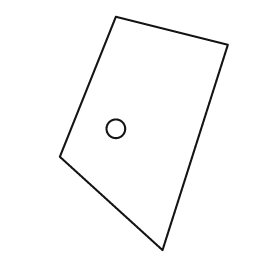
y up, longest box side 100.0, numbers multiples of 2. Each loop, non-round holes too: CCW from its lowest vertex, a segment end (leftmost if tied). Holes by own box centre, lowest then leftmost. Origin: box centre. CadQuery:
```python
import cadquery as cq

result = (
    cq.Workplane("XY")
    .moveTo(8.0, -50.0)
    .lineTo(36.0, 38.0)
    .lineTo(-12.0, 50.0)
    .lineTo(-36.0, -10.0)
    .close()
    .moveTo(-12.0, 2.0)
    .circle(4.0)
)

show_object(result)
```